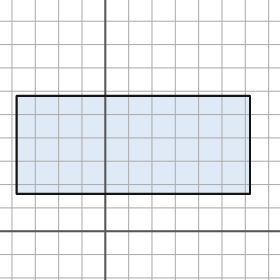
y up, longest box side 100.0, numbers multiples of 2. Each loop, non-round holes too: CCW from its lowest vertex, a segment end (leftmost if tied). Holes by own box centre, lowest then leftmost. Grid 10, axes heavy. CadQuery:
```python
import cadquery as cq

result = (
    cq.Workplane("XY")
    .moveTo(-38.0, 16.0)
    .lineTo(62.0, 16.0)
    .lineTo(62.0, 58.0)
    .lineTo(-38.0, 58.0)
    .close()
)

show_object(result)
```